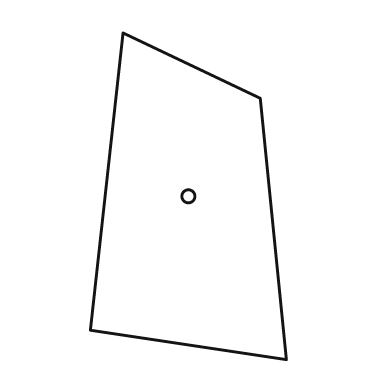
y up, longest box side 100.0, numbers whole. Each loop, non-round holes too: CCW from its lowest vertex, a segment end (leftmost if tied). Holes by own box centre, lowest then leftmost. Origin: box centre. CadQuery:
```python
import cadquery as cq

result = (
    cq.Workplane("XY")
    .moveTo(30.0, -50.0)
    .lineTo(22.0, 30.0)
    .lineTo(-20.0, 50.0)
    .lineTo(-30.0, -41.0)
    .close()
    .moveTo(0.0, 0.0)
    .circle(2.0)
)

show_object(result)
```